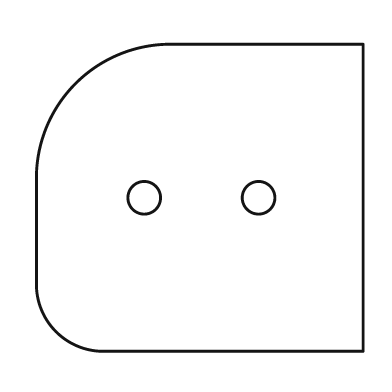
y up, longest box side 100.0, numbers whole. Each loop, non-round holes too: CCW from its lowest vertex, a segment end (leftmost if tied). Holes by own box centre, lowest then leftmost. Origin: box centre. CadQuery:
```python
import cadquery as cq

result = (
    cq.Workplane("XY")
    .moveTo(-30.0, -47.0)
    .lineTo(50.0, -47.0)
    .lineTo(50.0, 47.0)
    .lineTo(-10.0, 47.0)
    .threePointArc((-38.0, 35.0), (-50.0, 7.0))
    .lineTo(-50.0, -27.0)
    .threePointArc((-44.0, -41.0), (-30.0, -47.0))
    .close()
    .moveTo(-17.0, 0.0)
    .circle(5.0)
    .moveTo(18.0, 0.0)
    .circle(5.0)
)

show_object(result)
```